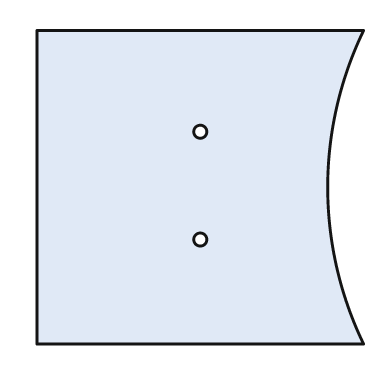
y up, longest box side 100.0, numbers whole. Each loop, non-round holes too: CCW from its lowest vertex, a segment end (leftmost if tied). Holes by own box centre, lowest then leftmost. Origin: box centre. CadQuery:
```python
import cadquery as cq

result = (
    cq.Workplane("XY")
    .moveTo(-50.0, -48.0)
    .lineTo(50.0, -48.0)
    .threePointArc((39.0, 0.0), (50.0, 48.0))
    .lineTo(-50.0, 48.0)
    .close()
    .moveTo(0.0, -16.0)
    .circle(2.0)
    .moveTo(0.0, 17.0)
    .circle(2.0)
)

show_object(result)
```